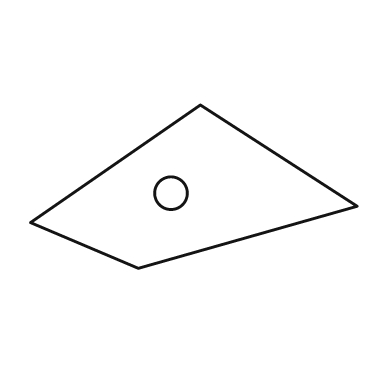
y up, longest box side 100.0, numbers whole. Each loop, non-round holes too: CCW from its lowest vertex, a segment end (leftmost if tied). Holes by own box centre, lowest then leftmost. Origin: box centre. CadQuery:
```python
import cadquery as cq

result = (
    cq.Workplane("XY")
    .moveTo(-17.0, -25.0)
    .lineTo(50.0, -6.0)
    .lineTo(2.0, 25.0)
    .lineTo(-50.0, -11.0)
    .close()
    .moveTo(-7.0, -2.0)
    .circle(5.0)
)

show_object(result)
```